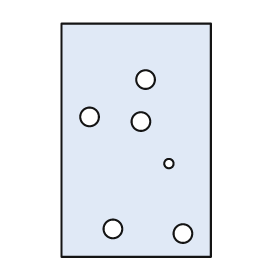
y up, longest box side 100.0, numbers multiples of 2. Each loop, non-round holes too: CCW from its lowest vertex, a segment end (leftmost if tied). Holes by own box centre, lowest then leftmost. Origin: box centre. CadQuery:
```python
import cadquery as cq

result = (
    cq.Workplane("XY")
    .moveTo(-32.0, -50.0)
    .lineTo(32.0, -50.0)
    .lineTo(32.0, 50.0)
    .lineTo(-32.0, 50.0)
    .close()
    .moveTo(20.0, -40.0)
    .circle(4.0)
    .moveTo(-10.0, -38.0)
    .circle(4.0)
    .moveTo(14.0, -10.0)
    .circle(2.0)
    .moveTo(2.0, 8.0)
    .circle(4.0)
    .moveTo(-20.0, 10.0)
    .circle(4.0)
    .moveTo(4.0, 26.0)
    .circle(4.0)
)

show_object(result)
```